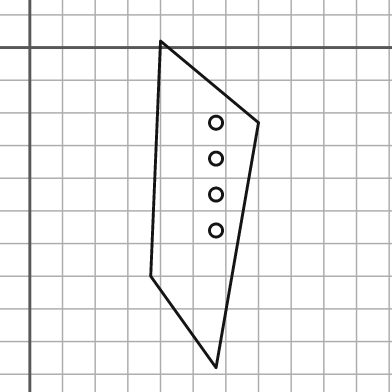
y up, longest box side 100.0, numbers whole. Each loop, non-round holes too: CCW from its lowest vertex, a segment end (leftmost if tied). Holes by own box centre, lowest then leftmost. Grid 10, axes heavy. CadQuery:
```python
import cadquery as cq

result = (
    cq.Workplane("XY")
    .moveTo(57.0, -98.0)
    .lineTo(70.0, -23.0)
    .lineTo(40.0, 2.0)
    .lineTo(37.0, -70.0)
    .close()
    .moveTo(57.0, -56.0)
    .circle(2.0)
    .moveTo(57.0, -45.0)
    .circle(2.0)
    .moveTo(57.0, -34.0)
    .circle(2.0)
    .moveTo(57.0, -23.0)
    .circle(2.0)
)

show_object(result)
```